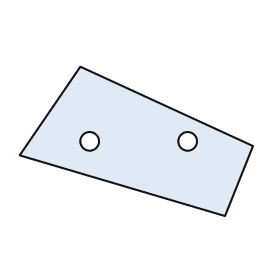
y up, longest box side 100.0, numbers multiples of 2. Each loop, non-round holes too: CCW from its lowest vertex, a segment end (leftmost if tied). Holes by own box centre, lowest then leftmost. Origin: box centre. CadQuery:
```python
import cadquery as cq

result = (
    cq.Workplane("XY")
    .moveTo(38.0, -32.0)
    .lineTo(50.0, -2.0)
    .lineTo(-24.0, 32.0)
    .lineTo(-50.0, -6.0)
    .close()
    .moveTo(-20.0, 0.0)
    .circle(4.0)
    .moveTo(22.0, 0.0)
    .circle(4.0)
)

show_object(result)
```